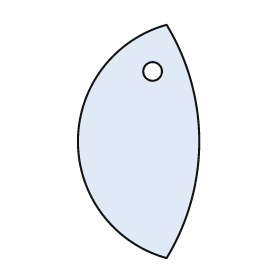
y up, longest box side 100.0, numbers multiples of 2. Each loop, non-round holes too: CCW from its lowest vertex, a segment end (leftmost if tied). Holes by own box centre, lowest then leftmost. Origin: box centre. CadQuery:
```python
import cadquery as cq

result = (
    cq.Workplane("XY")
    .moveTo(12.0, -50.0)
    .threePointArc((26.0, 0.0), (12.0, 50.0))
    .threePointArc((-26.0, 0.0), (12.0, -50.0))
    .close()
    .moveTo(6.0, 30.0)
    .circle(4.0)
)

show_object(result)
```